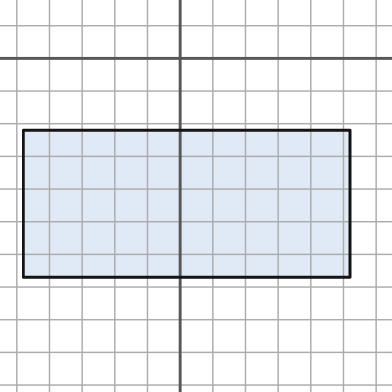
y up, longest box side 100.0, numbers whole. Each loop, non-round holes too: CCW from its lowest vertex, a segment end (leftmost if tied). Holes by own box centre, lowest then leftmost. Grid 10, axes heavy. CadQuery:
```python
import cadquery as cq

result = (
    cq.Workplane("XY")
    .moveTo(-48.0, -67.0)
    .lineTo(52.0, -67.0)
    .lineTo(52.0, -22.0)
    .lineTo(-48.0, -22.0)
    .close()
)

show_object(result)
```